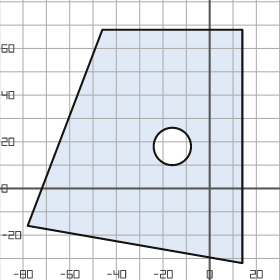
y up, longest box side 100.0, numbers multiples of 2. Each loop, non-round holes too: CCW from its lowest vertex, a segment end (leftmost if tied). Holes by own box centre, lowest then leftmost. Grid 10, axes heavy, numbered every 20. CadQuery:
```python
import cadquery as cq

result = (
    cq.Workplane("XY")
    .moveTo(14.0, -32.0)
    .lineTo(14.0, 68.0)
    .lineTo(-46.0, 68.0)
    .lineTo(-78.0, -16.0)
    .close()
    .moveTo(-16.0, 18.0)
    .circle(8.0)
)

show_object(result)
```